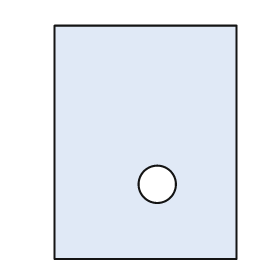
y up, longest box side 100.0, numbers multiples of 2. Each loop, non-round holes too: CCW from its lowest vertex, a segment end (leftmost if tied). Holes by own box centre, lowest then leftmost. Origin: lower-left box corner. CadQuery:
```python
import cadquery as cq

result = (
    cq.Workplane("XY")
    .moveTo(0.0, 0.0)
    .lineTo(78.0, 0.0)
    .lineTo(78.0, 100.0)
    .lineTo(0.0, 100.0)
    .close()
    .moveTo(44.0, 32.0)
    .circle(8.0)
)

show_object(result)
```